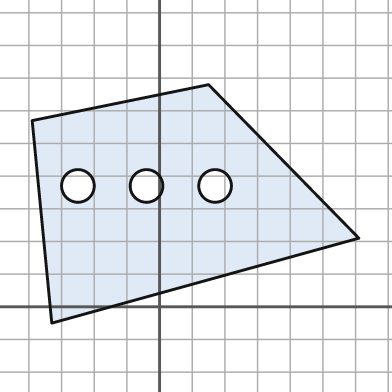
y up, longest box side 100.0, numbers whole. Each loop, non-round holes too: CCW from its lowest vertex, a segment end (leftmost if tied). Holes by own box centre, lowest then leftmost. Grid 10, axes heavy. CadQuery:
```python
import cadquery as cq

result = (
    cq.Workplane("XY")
    .moveTo(-33.0, -5.0)
    .lineTo(61.0, 21.0)
    .lineTo(15.0, 68.0)
    .lineTo(-39.0, 57.0)
    .close()
    .moveTo(-25.0, 37.0)
    .circle(5.0)
    .moveTo(-4.0, 37.0)
    .circle(5.0)
    .moveTo(17.0, 37.0)
    .circle(5.0)
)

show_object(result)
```